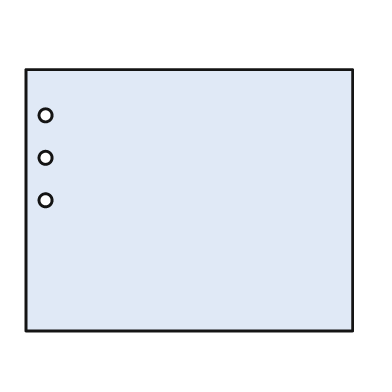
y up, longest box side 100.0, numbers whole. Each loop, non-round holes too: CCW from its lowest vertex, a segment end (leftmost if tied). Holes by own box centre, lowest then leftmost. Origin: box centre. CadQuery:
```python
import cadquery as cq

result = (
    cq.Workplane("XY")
    .moveTo(-50.0, -40.0)
    .lineTo(50.0, -40.0)
    .lineTo(50.0, 40.0)
    .lineTo(-50.0, 40.0)
    .close()
    .moveTo(-44.0, 0.0)
    .circle(2.0)
    .moveTo(-44.0, 13.0)
    .circle(2.0)
    .moveTo(-44.0, 26.0)
    .circle(2.0)
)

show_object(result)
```